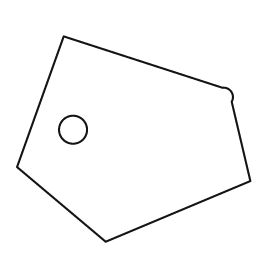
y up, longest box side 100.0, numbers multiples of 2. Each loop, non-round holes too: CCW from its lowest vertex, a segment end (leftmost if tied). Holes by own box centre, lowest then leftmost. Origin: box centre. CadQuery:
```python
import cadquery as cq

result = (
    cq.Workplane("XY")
    .moveTo(-12.0, -44.0)
    .lineTo(50.0, -18.0)
    .lineTo(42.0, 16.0)
    .threePointArc((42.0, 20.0), (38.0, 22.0))
    .lineTo(-30.0, 44.0)
    .lineTo(-50.0, -12.0)
    .close()
    .moveTo(-26.0, 4.0)
    .circle(6.0)
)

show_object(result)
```